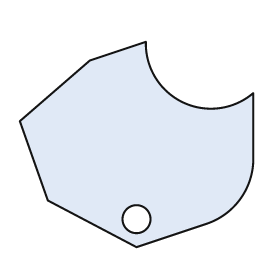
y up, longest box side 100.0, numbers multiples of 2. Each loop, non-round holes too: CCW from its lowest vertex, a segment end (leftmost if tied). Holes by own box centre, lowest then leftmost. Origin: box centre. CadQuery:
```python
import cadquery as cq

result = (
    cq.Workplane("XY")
    .moveTo(0.0, -44.0)
    .lineTo(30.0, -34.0)
    .threePointArc((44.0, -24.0), (50.0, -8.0))
    .lineTo(50.0, 22.0)
    .threePointArc((20.0, 18.0), (4.0, 44.0))
    .lineTo(-20.0, 36.0)
    .lineTo(-50.0, 10.0)
    .lineTo(-38.0, -24.0)
    .close()
    .moveTo(0.0, -32.0)
    .circle(6.0)
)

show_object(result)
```